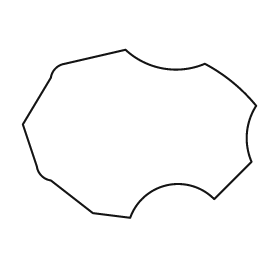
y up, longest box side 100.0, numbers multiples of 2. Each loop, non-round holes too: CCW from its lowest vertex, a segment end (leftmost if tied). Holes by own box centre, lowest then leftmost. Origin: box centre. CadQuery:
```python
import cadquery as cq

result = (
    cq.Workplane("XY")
    .moveTo(-4.0, -36.0)
    .threePointArc((12.0, -22.0), (32.0, -28.0))
    .lineTo(48.0, -12.0)
    .threePointArc((46.0, 0.0), (50.0, 12.0))
    .threePointArc((40.0, 22.0), (28.0, 30.0))
    .threePointArc((10.0, 28.0), (-6.0, 36.0))
    .lineTo(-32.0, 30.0)
    .threePointArc((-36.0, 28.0), (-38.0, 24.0))
    .lineTo(-50.0, 4.0)
    .lineTo(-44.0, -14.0)
    .threePointArc((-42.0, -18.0), (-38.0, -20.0))
    .lineTo(-20.0, -34.0)
    .close()
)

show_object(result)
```